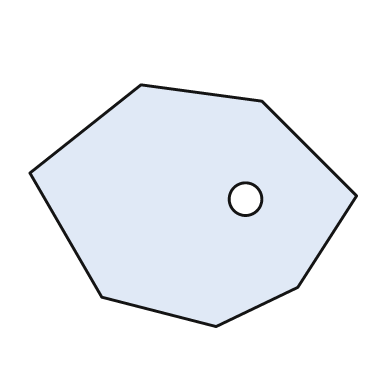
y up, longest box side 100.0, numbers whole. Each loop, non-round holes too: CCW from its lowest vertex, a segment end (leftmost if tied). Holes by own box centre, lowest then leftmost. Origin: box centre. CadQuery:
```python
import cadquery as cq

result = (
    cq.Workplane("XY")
    .moveTo(7.0, -37.0)
    .lineTo(32.0, -25.0)
    .lineTo(50.0, 3.0)
    .lineTo(21.0, 32.0)
    .lineTo(-16.0, 37.0)
    .lineTo(-50.0, 10.0)
    .lineTo(-28.0, -28.0)
    .close()
    .moveTo(16.0, 2.0)
    .circle(5.0)
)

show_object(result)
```